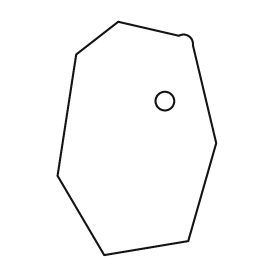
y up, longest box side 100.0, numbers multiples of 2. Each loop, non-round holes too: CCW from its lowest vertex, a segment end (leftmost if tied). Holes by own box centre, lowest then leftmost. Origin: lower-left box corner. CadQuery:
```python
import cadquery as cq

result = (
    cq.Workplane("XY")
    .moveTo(20.0, 0.0)
    .lineTo(56.0, 6.0)
    .lineTo(68.0, 48.0)
    .lineTo(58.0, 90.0)
    .threePointArc((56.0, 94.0), (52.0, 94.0))
    .lineTo(26.0, 100.0)
    .lineTo(8.0, 86.0)
    .lineTo(0.0, 34.0)
    .close()
    .moveTo(46.0, 66.0)
    .circle(4.0)
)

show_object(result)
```